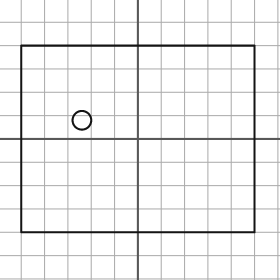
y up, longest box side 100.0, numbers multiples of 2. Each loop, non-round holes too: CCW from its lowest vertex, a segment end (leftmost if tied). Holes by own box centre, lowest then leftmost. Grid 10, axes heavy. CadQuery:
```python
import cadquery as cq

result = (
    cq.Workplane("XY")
    .moveTo(-50.0, -40.0)
    .lineTo(50.0, -40.0)
    .lineTo(50.0, 40.0)
    .lineTo(-50.0, 40.0)
    .close()
    .moveTo(-24.0, 8.0)
    .circle(4.0)
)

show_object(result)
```